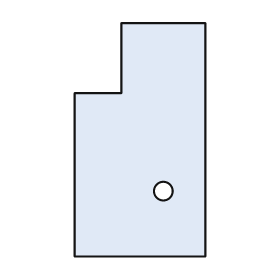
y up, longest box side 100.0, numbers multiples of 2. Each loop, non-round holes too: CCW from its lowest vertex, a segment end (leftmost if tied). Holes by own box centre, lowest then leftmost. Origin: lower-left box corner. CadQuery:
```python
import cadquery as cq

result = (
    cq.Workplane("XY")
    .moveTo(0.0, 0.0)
    .lineTo(56.0, 0.0)
    .lineTo(56.0, 100.0)
    .lineTo(20.0, 100.0)
    .lineTo(20.0, 70.0)
    .lineTo(0.0, 70.0)
    .close()
    .moveTo(38.0, 28.0)
    .circle(4.0)
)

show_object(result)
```